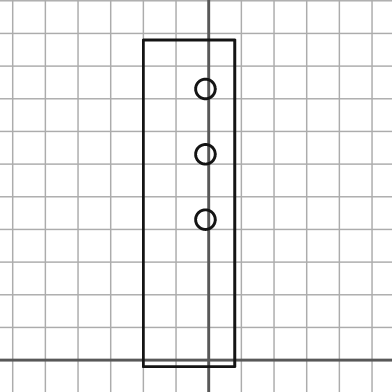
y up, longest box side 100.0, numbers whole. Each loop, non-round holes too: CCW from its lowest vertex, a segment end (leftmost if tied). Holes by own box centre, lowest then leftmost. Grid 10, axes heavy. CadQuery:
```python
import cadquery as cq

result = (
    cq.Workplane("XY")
    .moveTo(-20.0, -2.0)
    .lineTo(8.0, -2.0)
    .lineTo(8.0, 98.0)
    .lineTo(-20.0, 98.0)
    .close()
    .moveTo(-1.0, 43.0)
    .circle(3.0)
    .moveTo(-1.0, 63.0)
    .circle(3.0)
    .moveTo(-1.0, 83.0)
    .circle(3.0)
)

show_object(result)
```